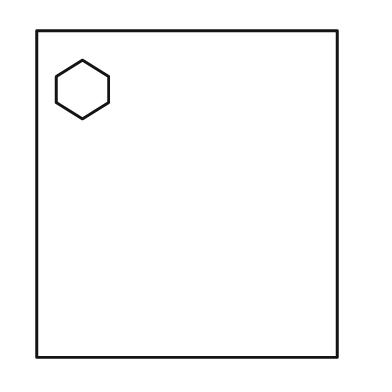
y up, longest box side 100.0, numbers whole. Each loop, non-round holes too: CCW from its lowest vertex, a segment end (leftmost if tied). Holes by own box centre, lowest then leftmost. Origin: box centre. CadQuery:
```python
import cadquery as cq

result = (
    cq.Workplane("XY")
    .moveTo(-46.0, -50.0)
    .lineTo(46.0, -50.0)
    .lineTo(46.0, 50.0)
    .lineTo(-46.0, 50.0)
    .close()
    .moveTo(-32.0, 23.0)
    .lineTo(-24.0, 28.0)
    .lineTo(-24.0, 36.0)
    .lineTo(-32.0, 41.0)
    .lineTo(-40.0, 36.0)
    .lineTo(-40.0, 28.0)
    .close()
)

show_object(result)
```